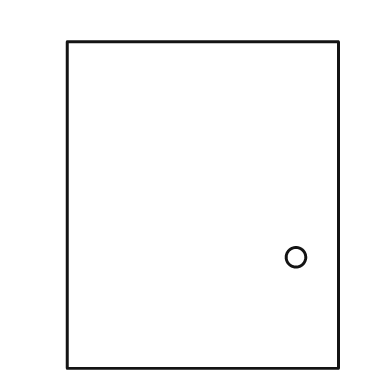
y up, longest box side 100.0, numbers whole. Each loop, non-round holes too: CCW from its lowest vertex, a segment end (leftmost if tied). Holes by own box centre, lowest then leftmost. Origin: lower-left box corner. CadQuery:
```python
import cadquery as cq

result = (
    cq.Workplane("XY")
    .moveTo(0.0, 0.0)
    .lineTo(83.0, 0.0)
    .lineTo(83.0, 100.0)
    .lineTo(0.0, 100.0)
    .close()
    .moveTo(70.0, 34.0)
    .circle(3.0)
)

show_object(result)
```